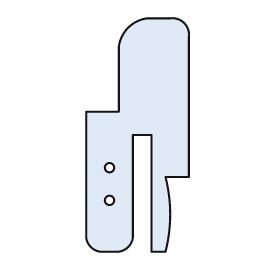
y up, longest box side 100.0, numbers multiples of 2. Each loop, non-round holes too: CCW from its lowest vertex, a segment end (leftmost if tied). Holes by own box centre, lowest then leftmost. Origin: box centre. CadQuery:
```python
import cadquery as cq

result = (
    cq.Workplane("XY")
    .moveTo(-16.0, -50.0)
    .lineTo(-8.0, -50.0)
    .threePointArc((-4.0, -48.0), (-2.0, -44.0))
    .lineTo(-2.0, 0.0)
    .lineTo(6.0, 0.0)
    .lineTo(6.0, -50.0)
    .lineTo(12.0, -50.0)
    .threePointArc((14.0, -34.0), (12.0, -18.0))
    .lineTo(22.0, -18.0)
    .lineTo(22.0, 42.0)
    .threePointArc((20.0, 48.0), (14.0, 50.0))
    .lineTo(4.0, 50.0)
    .threePointArc((-4.0, 46.0), (-8.0, 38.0))
    .lineTo(-8.0, 10.0)
    .lineTo(-22.0, 10.0)
    .lineTo(-22.0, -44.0)
    .threePointArc((-20.0, -48.0), (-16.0, -50.0))
    .close()
    .moveTo(-12.0, -28.0)
    .circle(2.0)
    .moveTo(-12.0, -14.0)
    .circle(2.0)
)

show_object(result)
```